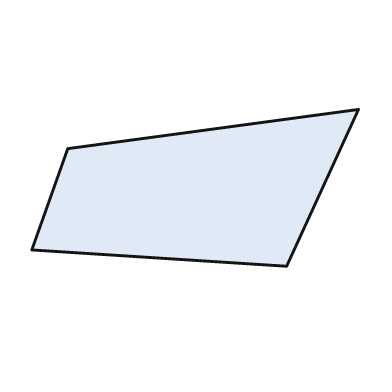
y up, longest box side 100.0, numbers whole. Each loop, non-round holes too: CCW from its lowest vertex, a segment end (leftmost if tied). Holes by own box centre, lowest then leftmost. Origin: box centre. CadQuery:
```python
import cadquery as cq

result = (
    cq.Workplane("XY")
    .moveTo(28.0, -24.0)
    .lineTo(50.0, 24.0)
    .lineTo(-39.0, 12.0)
    .lineTo(-50.0, -19.0)
    .close()
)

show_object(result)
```